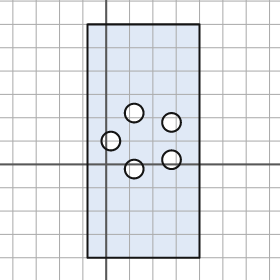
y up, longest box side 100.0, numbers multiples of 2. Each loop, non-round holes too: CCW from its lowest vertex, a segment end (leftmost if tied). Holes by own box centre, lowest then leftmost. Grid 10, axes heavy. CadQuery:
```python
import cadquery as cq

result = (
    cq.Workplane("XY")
    .moveTo(-8.0, -40.0)
    .lineTo(40.0, -40.0)
    .lineTo(40.0, 60.0)
    .lineTo(-8.0, 60.0)
    .close()
    .moveTo(12.0, -2.0)
    .circle(4.0)
    .moveTo(28.0, 2.0)
    .circle(4.0)
    .moveTo(2.0, 10.0)
    .circle(4.0)
    .moveTo(28.0, 18.0)
    .circle(4.0)
    .moveTo(12.0, 22.0)
    .circle(4.0)
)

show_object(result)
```